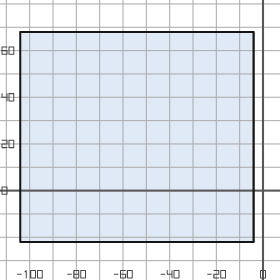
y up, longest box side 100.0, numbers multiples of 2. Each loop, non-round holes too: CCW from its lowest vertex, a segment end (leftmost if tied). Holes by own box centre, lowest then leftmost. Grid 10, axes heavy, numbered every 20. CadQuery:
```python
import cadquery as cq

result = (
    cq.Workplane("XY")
    .moveTo(-104.0, -22.0)
    .lineTo(-4.0, -22.0)
    .lineTo(-4.0, 68.0)
    .lineTo(-104.0, 68.0)
    .close()
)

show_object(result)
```